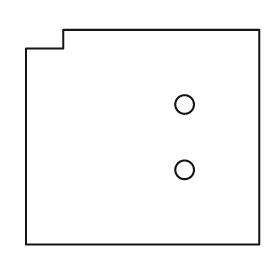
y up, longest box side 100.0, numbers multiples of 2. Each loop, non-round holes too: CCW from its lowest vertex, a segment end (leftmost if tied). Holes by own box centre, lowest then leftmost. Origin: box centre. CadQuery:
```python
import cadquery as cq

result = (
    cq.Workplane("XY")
    .moveTo(-50.0, -46.0)
    .lineTo(50.0, -46.0)
    .lineTo(50.0, 46.0)
    .lineTo(-34.0, 46.0)
    .lineTo(-34.0, 38.0)
    .lineTo(-50.0, 38.0)
    .close()
    .moveTo(18.0, -14.0)
    .circle(4.0)
    .moveTo(18.0, 14.0)
    .circle(4.0)
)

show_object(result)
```